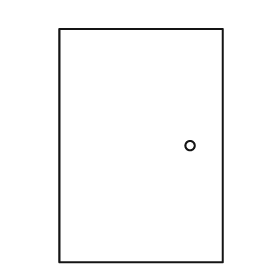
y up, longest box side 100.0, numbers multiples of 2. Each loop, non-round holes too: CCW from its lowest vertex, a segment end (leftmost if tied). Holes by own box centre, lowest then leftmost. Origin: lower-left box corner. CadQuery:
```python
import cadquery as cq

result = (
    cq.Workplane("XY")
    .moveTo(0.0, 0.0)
    .lineTo(70.0, 0.0)
    .lineTo(70.0, 100.0)
    .lineTo(0.0, 100.0)
    .close()
    .moveTo(56.0, 50.0)
    .circle(2.0)
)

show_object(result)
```